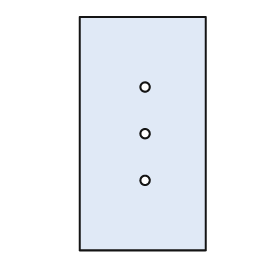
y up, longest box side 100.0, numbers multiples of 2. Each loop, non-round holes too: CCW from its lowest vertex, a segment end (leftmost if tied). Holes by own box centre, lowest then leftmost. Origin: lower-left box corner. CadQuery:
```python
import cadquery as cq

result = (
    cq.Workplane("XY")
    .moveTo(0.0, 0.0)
    .lineTo(54.0, 0.0)
    .lineTo(54.0, 100.0)
    .lineTo(0.0, 100.0)
    .close()
    .moveTo(28.0, 30.0)
    .circle(2.0)
    .moveTo(28.0, 50.0)
    .circle(2.0)
    .moveTo(28.0, 70.0)
    .circle(2.0)
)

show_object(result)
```